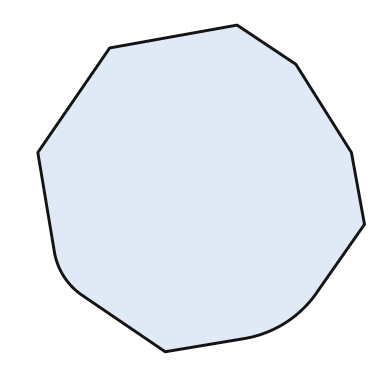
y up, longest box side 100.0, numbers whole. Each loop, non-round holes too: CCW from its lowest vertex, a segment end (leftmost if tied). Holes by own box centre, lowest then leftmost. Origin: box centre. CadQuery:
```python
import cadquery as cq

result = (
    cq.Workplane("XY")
    .moveTo(-11.0, -50.0)
    .lineTo(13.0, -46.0)
    .threePointArc((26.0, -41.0), (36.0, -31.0))
    .lineTo(50.0, -11.0)
    .lineTo(46.0, 11.0)
    .lineTo(29.0, 38.0)
    .lineTo(11.0, 50.0)
    .lineTo(-28.0, 43.0)
    .lineTo(-50.0, 11.0)
    .lineTo(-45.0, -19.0)
    .threePointArc((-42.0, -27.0), (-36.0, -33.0))
    .close()
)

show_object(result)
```